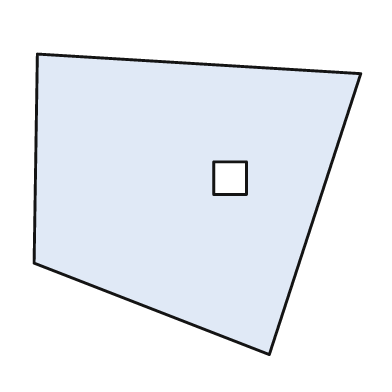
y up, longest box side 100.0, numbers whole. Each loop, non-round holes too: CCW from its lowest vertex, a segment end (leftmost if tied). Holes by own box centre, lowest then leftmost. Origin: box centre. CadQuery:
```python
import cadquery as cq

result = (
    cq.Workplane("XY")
    .moveTo(22.0, -46.0)
    .lineTo(50.0, 40.0)
    .lineTo(-49.0, 46.0)
    .lineTo(-50.0, -18.0)
    .close()
    .moveTo(5.0, 3.0)
    .lineTo(15.0, 3.0)
    .lineTo(15.0, 13.0)
    .lineTo(5.0, 13.0)
    .close()
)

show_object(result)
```